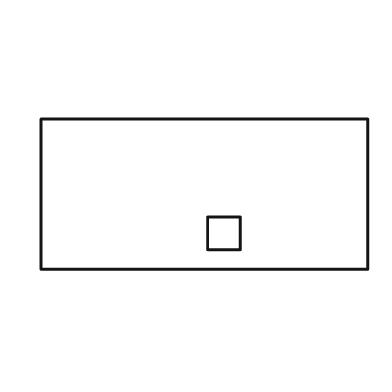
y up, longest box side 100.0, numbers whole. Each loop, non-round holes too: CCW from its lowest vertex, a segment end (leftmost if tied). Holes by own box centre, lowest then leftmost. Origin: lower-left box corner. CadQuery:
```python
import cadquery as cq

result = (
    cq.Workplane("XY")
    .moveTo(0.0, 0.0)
    .lineTo(100.0, 0.0)
    .lineTo(100.0, 46.0)
    .lineTo(0.0, 46.0)
    .close()
    .moveTo(51.0, 6.0)
    .lineTo(61.0, 6.0)
    .lineTo(61.0, 16.0)
    .lineTo(51.0, 16.0)
    .close()
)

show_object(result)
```